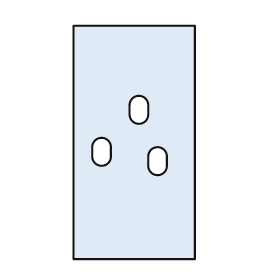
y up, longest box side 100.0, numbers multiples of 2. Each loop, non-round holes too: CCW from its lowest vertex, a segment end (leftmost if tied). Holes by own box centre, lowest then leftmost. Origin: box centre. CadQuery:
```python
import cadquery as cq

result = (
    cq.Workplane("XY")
    .moveTo(-26.0, -50.0)
    .lineTo(26.0, -50.0)
    .lineTo(26.0, 50.0)
    .lineTo(-26.0, 50.0)
    .close()
    .moveTo(6.0, -10.0)
    .threePointArc((10.0, -14.0), (14.0, -10.0))
    .lineTo(14.0, -6.0)
    .threePointArc((10.0, -2.0), (6.0, -6.0))
    .close()
    .moveTo(-18.0, -6.0)
    .threePointArc((-14.0, -10.0), (-10.0, -6.0))
    .lineTo(-10.0, -2.0)
    .threePointArc((-14.0, 2.0), (-18.0, -2.0))
    .close()
    .moveTo(-2.0, 12.0)
    .threePointArc((2.0, 8.0), (6.0, 12.0))
    .lineTo(6.0, 16.0)
    .threePointArc((2.0, 20.0), (-2.0, 16.0))
    .close()
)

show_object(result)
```